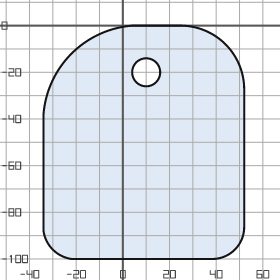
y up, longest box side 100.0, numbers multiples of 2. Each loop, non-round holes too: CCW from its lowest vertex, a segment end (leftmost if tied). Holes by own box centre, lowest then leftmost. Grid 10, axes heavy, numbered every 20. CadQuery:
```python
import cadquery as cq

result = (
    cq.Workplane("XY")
    .moveTo(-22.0, -100.0)
    .lineTo(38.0, -100.0)
    .threePointArc((48.0, -96.0), (52.0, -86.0))
    .lineTo(52.0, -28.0)
    .threePointArc((44.0, -8.0), (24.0, 0.0))
    .lineTo(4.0, 0.0)
    .threePointArc((-22.0, -12.0), (-34.0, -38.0))
    .lineTo(-34.0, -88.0)
    .threePointArc((-30.0, -96.0), (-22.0, -100.0))
    .close()
    .moveTo(10.0, -20.0)
    .circle(6.0)
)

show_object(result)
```